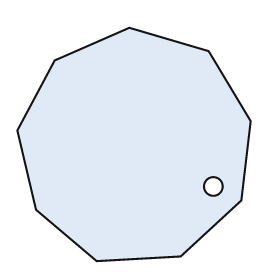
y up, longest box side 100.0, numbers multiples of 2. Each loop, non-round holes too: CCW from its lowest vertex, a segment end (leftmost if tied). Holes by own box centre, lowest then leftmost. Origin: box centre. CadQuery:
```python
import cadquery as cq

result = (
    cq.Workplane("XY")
    .moveTo(-16.0, -50.0)
    .lineTo(20.0, -48.0)
    .lineTo(46.0, -24.0)
    .lineTo(50.0, 10.0)
    .lineTo(32.0, 40.0)
    .lineTo(-2.0, 50.0)
    .lineTo(-34.0, 36.0)
    .lineTo(-50.0, 6.0)
    .lineTo(-42.0, -28.0)
    .close()
    .moveTo(34.0, -18.0)
    .circle(4.0)
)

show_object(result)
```